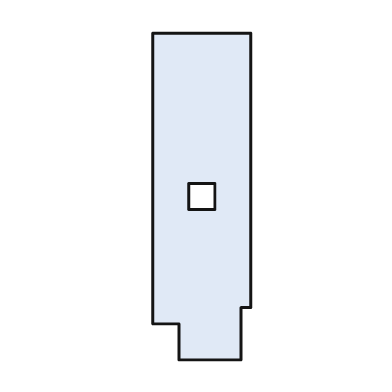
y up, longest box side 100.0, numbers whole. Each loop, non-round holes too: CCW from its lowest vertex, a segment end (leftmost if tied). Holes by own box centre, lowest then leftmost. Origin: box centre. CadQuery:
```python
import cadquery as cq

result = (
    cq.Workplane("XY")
    .moveTo(-7.0, -50.0)
    .lineTo(12.0, -50.0)
    .lineTo(12.0, -34.0)
    .lineTo(15.0, -34.0)
    .lineTo(15.0, 50.0)
    .lineTo(-15.0, 50.0)
    .lineTo(-15.0, -39.0)
    .lineTo(-7.0, -39.0)
    .close()
    .moveTo(-4.0, -4.0)
    .lineTo(4.0, -4.0)
    .lineTo(4.0, 4.0)
    .lineTo(-4.0, 4.0)
    .close()
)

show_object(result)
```